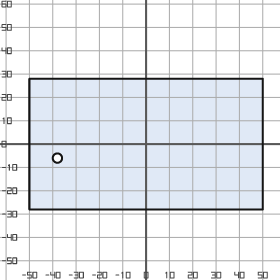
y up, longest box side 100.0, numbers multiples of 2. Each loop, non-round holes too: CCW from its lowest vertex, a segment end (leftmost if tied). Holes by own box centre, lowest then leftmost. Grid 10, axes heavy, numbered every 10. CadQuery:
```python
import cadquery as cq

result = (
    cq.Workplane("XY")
    .moveTo(-50.0, -28.0)
    .lineTo(50.0, -28.0)
    .lineTo(50.0, 28.0)
    .lineTo(-50.0, 28.0)
    .close()
    .moveTo(-38.0, -6.0)
    .circle(2.0)
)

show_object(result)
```